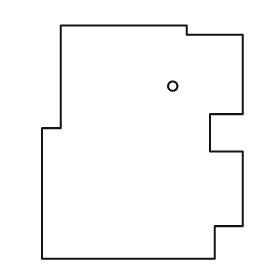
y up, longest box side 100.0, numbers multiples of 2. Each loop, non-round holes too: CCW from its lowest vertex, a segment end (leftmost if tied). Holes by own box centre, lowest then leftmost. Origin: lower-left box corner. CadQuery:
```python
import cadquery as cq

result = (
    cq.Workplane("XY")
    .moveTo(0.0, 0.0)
    .lineTo(74.0, 0.0)
    .lineTo(74.0, 14.0)
    .lineTo(86.0, 14.0)
    .lineTo(86.0, 46.0)
    .lineTo(72.0, 46.0)
    .lineTo(72.0, 62.0)
    .lineTo(86.0, 62.0)
    .lineTo(86.0, 96.0)
    .lineTo(62.0, 96.0)
    .lineTo(62.0, 100.0)
    .lineTo(8.0, 100.0)
    .lineTo(8.0, 56.0)
    .lineTo(0.0, 56.0)
    .close()
    .moveTo(56.0, 74.0)
    .circle(2.0)
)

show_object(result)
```